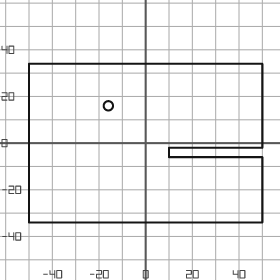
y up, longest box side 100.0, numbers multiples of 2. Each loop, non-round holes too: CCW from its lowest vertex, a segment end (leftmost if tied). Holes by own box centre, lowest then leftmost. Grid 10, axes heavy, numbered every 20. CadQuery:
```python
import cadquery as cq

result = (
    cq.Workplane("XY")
    .moveTo(-50.0, -34.0)
    .lineTo(50.0, -34.0)
    .lineTo(50.0, -6.0)
    .lineTo(10.0, -6.0)
    .lineTo(10.0, -2.0)
    .lineTo(50.0, -2.0)
    .lineTo(50.0, 34.0)
    .lineTo(-50.0, 34.0)
    .close()
    .moveTo(-16.0, 16.0)
    .circle(2.0)
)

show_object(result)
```